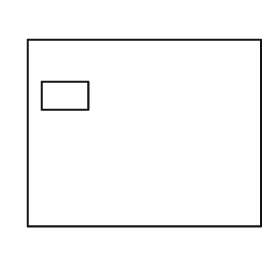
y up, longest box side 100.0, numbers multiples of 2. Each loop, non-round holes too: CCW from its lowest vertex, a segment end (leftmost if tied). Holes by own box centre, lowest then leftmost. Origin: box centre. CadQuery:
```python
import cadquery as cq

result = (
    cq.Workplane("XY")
    .moveTo(-50.0, -40.0)
    .lineTo(50.0, -40.0)
    .lineTo(50.0, 40.0)
    .lineTo(-50.0, 40.0)
    .close()
    .moveTo(-44.0, 10.0)
    .lineTo(-24.0, 10.0)
    .lineTo(-24.0, 22.0)
    .lineTo(-44.0, 22.0)
    .close()
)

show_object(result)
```